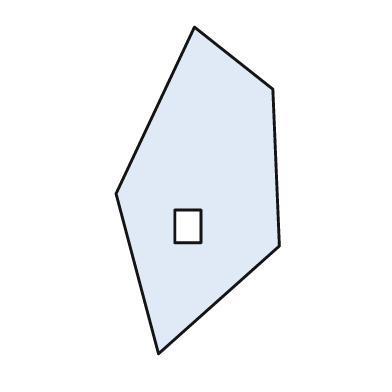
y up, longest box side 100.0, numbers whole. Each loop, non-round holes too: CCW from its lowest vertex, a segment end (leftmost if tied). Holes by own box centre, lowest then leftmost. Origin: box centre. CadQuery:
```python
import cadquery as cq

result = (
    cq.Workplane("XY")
    .moveTo(-12.0, -50.0)
    .lineTo(25.0, -17.0)
    .lineTo(23.0, 31.0)
    .lineTo(-1.0, 50.0)
    .lineTo(-25.0, -1.0)
    .close()
    .moveTo(-7.0, -16.0)
    .lineTo(1.0, -16.0)
    .lineTo(1.0, -6.0)
    .lineTo(-7.0, -6.0)
    .close()
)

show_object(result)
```